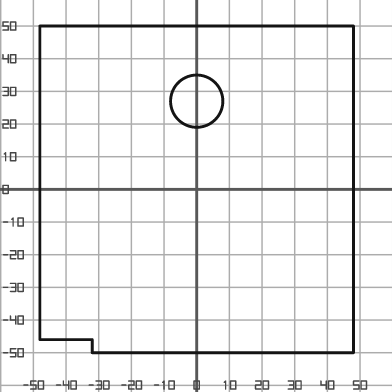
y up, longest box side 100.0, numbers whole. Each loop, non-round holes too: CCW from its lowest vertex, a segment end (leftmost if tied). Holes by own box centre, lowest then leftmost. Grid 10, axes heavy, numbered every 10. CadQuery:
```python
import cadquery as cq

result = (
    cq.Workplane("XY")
    .moveTo(-32.0, -50.0)
    .lineTo(48.0, -50.0)
    .lineTo(48.0, 50.0)
    .lineTo(-48.0, 50.0)
    .lineTo(-48.0, -46.0)
    .lineTo(-32.0, -46.0)
    .close()
    .moveTo(0.0, 27.0)
    .circle(8.0)
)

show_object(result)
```